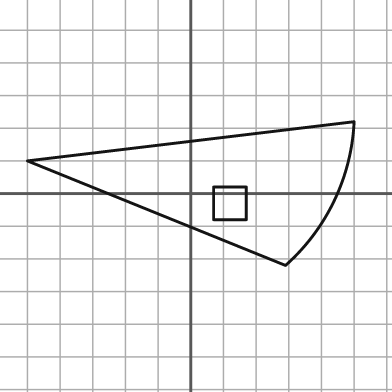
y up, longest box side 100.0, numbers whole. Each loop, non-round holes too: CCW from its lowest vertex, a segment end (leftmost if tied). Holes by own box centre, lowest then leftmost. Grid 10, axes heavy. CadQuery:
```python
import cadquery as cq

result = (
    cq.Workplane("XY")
    .moveTo(29.0, -22.0)
    .threePointArc((44.0, -2.0), (50.0, 22.0))
    .lineTo(-50.0, 10.0)
    .close()
    .moveTo(7.0, -8.0)
    .lineTo(17.0, -8.0)
    .lineTo(17.0, 2.0)
    .lineTo(7.0, 2.0)
    .close()
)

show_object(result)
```